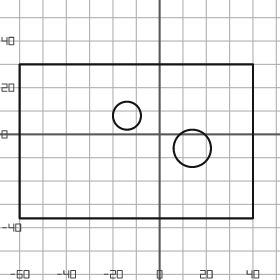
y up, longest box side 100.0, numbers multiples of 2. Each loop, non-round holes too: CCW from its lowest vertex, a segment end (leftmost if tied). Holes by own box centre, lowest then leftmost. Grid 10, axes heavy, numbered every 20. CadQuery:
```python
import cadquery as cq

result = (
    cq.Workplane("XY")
    .moveTo(-60.0, -36.0)
    .lineTo(40.0, -36.0)
    .lineTo(40.0, 30.0)
    .lineTo(-60.0, 30.0)
    .close()
    .moveTo(14.0, -6.0)
    .circle(8.0)
    .moveTo(-14.0, 8.0)
    .circle(6.0)
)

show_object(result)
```